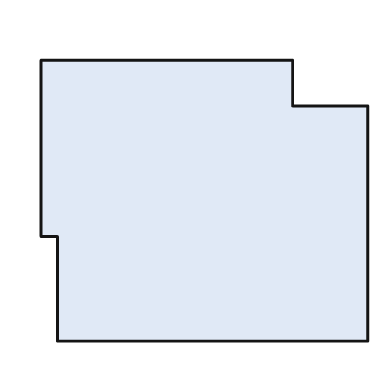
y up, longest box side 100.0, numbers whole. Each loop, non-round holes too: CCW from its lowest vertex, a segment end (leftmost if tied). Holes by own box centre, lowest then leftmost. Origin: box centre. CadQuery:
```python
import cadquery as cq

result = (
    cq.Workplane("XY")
    .moveTo(-45.0, -43.0)
    .lineTo(50.0, -43.0)
    .lineTo(50.0, 29.0)
    .lineTo(27.0, 29.0)
    .lineTo(27.0, 43.0)
    .lineTo(-50.0, 43.0)
    .lineTo(-50.0, -11.0)
    .lineTo(-45.0, -11.0)
    .close()
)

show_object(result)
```